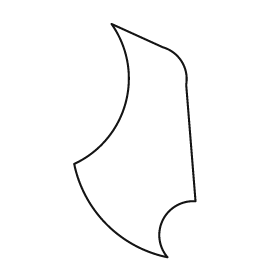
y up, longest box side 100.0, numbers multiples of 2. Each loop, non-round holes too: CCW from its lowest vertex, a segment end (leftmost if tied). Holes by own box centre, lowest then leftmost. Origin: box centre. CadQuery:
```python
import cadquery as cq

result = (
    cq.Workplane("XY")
    .moveTo(14.0, -50.0)
    .threePointArc((12.0, -34.0), (26.0, -26.0))
    .lineTo(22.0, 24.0)
    .threePointArc((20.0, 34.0), (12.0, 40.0))
    .lineTo(-10.0, 50.0)
    .threePointArc((-4.0, 16.0), (-26.0, -10.0))
    .threePointArc((-12.0, -36.0), (14.0, -50.0))
    .close()
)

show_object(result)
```